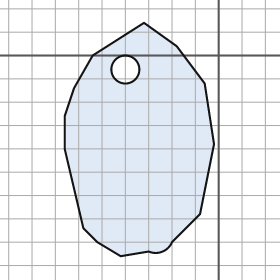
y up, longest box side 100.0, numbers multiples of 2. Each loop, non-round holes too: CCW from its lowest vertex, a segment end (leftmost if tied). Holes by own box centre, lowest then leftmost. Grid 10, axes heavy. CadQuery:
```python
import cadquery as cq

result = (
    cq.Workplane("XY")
    .moveTo(-42.0, -86.0)
    .lineTo(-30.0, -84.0)
    .threePointArc((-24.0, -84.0), (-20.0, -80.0))
    .lineTo(-8.0, -68.0)
    .lineTo(-2.0, -38.0)
    .lineTo(-6.0, -12.0)
    .lineTo(-18.0, 4.0)
    .lineTo(-32.0, 14.0)
    .lineTo(-54.0, 0.0)
    .lineTo(-62.0, -14.0)
    .lineTo(-66.0, -26.0)
    .lineTo(-66.0, -40.0)
    .lineTo(-58.0, -74.0)
    .lineTo(-52.0, -80.0)
    .close()
    .moveTo(-40.0, -6.0)
    .circle(6.0)
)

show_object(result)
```